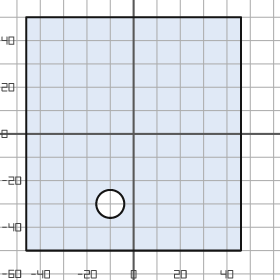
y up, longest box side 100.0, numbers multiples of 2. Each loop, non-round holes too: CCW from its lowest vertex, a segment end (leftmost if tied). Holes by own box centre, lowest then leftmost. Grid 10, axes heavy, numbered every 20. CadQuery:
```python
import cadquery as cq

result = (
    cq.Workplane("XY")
    .moveTo(-46.0, -50.0)
    .lineTo(46.0, -50.0)
    .lineTo(46.0, 50.0)
    .lineTo(-46.0, 50.0)
    .close()
    .moveTo(-10.0, -30.0)
    .circle(6.0)
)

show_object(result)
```